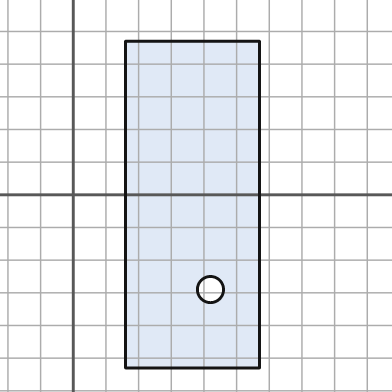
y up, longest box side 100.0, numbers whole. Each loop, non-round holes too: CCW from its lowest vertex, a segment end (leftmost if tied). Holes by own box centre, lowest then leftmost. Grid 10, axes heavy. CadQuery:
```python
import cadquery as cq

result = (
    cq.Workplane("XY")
    .moveTo(16.0, -53.0)
    .lineTo(57.0, -53.0)
    .lineTo(57.0, 47.0)
    .lineTo(16.0, 47.0)
    .close()
    .moveTo(42.0, -29.0)
    .circle(4.0)
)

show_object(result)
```